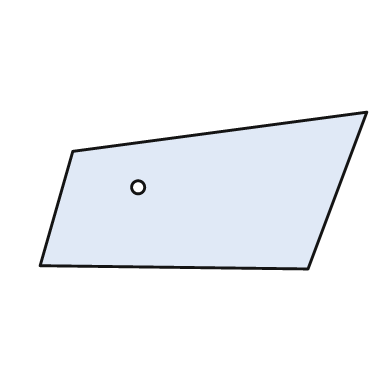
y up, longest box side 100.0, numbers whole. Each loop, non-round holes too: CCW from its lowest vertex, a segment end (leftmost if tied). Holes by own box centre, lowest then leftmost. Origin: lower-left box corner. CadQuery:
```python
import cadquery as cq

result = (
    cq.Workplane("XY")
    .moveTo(82.0, 0.0)
    .lineTo(100.0, 48.0)
    .lineTo(10.0, 36.0)
    .lineTo(0.0, 1.0)
    .close()
    .moveTo(30.0, 25.0)
    .circle(2.0)
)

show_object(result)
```